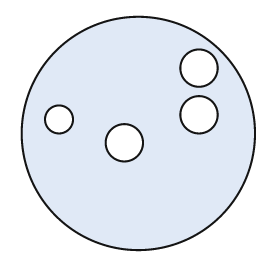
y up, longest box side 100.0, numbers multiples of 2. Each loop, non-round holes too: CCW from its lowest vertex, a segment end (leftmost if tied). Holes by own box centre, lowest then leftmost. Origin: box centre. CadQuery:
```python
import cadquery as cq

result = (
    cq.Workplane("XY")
    .moveTo(0.0, 0.0)
    .circle(50.0)
    .moveTo(-6.0, -4.0)
    .circle(8.0)
    .moveTo(-34.0, 6.0)
    .circle(6.0)
    .moveTo(26.0, 8.0)
    .circle(8.0)
    .moveTo(26.0, 28.0)
    .circle(8.0)
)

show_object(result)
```